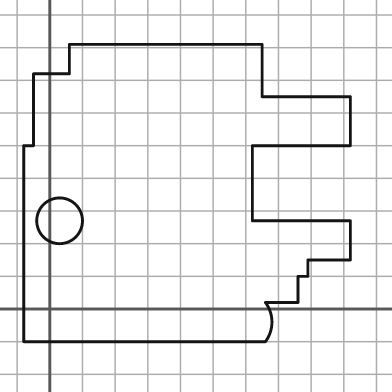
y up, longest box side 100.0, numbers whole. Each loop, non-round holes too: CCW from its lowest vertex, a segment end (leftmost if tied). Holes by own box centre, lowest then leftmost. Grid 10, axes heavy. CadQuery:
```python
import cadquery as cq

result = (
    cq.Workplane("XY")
    .moveTo(-8.0, -10.0)
    .lineTo(66.0, -10.0)
    .threePointArc((68.0, -4.0), (66.0, 2.0))
    .lineTo(76.0, 2.0)
    .lineTo(76.0, 10.0)
    .lineTo(79.0, 10.0)
    .lineTo(79.0, 15.0)
    .lineTo(92.0, 15.0)
    .lineTo(92.0, 27.0)
    .lineTo(62.0, 27.0)
    .lineTo(62.0, 50.0)
    .lineTo(92.0, 50.0)
    .lineTo(92.0, 65.0)
    .lineTo(65.0, 65.0)
    .lineTo(65.0, 81.0)
    .lineTo(6.0, 81.0)
    .lineTo(6.0, 72.0)
    .lineTo(-5.0, 72.0)
    .lineTo(-5.0, 50.0)
    .lineTo(-8.0, 50.0)
    .close()
    .moveTo(3.0, 27.0)
    .circle(7.0)
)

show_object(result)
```